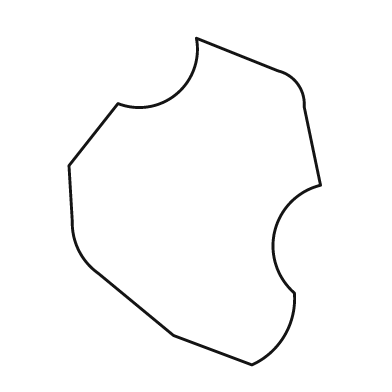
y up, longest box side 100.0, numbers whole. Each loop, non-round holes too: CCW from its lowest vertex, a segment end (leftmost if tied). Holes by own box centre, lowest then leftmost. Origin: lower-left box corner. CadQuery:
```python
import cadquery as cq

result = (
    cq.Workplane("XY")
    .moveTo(56.0, 0.0)
    .threePointArc((66.0, 9.0), (69.0, 22.0))
    .threePointArc((63.0, 41.0), (77.0, 55.0))
    .lineTo(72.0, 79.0)
    .threePointArc((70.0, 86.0), (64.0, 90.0))
    .lineTo(39.0, 100.0)
    .threePointArc((33.0, 83.0), (15.0, 80.0))
    .lineTo(0.0, 61.0)
    .lineTo(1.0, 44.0)
    .threePointArc((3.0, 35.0), (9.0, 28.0))
    .lineTo(32.0, 9.0)
    .close()
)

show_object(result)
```